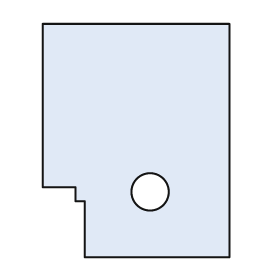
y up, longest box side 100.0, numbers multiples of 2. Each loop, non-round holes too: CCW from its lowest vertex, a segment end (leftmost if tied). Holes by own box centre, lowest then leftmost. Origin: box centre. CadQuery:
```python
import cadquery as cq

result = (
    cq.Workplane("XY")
    .moveTo(-22.0, -50.0)
    .lineTo(40.0, -50.0)
    .lineTo(40.0, 50.0)
    .lineTo(-40.0, 50.0)
    .lineTo(-40.0, -20.0)
    .lineTo(-26.0, -20.0)
    .lineTo(-26.0, -26.0)
    .lineTo(-22.0, -26.0)
    .close()
    .moveTo(6.0, -22.0)
    .circle(8.0)
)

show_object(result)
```